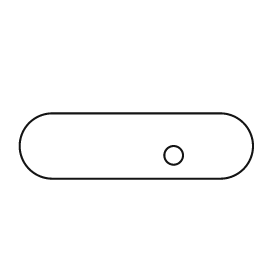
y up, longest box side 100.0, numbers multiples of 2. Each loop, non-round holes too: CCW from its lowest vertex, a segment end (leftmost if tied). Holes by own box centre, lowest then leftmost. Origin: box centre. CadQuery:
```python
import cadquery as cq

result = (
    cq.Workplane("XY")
    .moveTo(-36.0, -14.0)
    .lineTo(36.0, -14.0)
    .threePointArc((50.0, 0.0), (36.0, 14.0))
    .lineTo(-36.0, 14.0)
    .threePointArc((-50.0, 0.0), (-36.0, -14.0))
    .close()
    .moveTo(16.0, -4.0)
    .circle(4.0)
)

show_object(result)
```